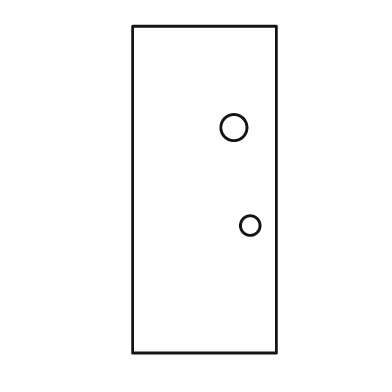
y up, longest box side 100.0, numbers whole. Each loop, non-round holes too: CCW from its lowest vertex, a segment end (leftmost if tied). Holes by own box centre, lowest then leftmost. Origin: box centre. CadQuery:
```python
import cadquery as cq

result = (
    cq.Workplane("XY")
    .moveTo(-22.0, -50.0)
    .lineTo(22.0, -50.0)
    .lineTo(22.0, 50.0)
    .lineTo(-22.0, 50.0)
    .close()
    .moveTo(14.0, -11.0)
    .circle(3.0)
    .moveTo(9.0, 19.0)
    .circle(4.0)
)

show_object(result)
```